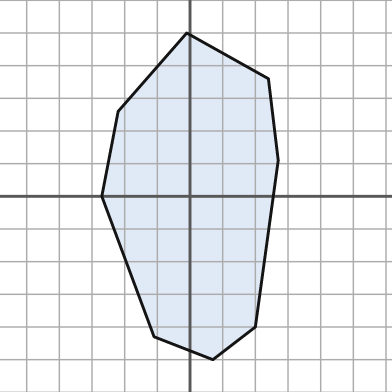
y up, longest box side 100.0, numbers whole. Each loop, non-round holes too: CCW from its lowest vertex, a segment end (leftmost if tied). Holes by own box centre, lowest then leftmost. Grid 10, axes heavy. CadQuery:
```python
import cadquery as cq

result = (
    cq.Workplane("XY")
    .moveTo(7.0, -50.0)
    .lineTo(20.0, -40.0)
    .lineTo(27.0, 11.0)
    .lineTo(24.0, 36.0)
    .lineTo(-1.0, 50.0)
    .lineTo(-22.0, 26.0)
    .lineTo(-27.0, 0.0)
    .lineTo(-11.0, -43.0)
    .close()
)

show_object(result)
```